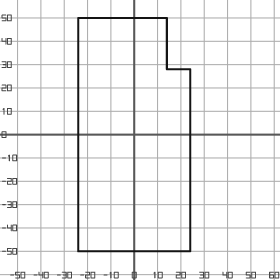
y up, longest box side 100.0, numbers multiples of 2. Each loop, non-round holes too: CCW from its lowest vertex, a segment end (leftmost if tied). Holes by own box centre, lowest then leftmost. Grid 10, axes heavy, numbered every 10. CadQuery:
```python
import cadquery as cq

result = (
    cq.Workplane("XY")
    .moveTo(-24.0, -50.0)
    .lineTo(24.0, -50.0)
    .lineTo(24.0, 28.0)
    .lineTo(14.0, 28.0)
    .lineTo(14.0, 50.0)
    .lineTo(-24.0, 50.0)
    .close()
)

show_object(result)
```